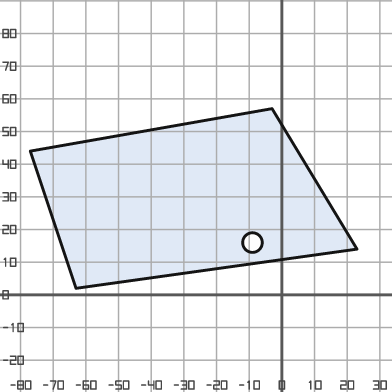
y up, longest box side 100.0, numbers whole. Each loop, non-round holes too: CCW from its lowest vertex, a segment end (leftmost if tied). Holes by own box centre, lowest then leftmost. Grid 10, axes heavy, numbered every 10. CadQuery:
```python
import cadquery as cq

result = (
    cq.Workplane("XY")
    .moveTo(-63.0, 2.0)
    .lineTo(23.0, 14.0)
    .lineTo(-3.0, 57.0)
    .lineTo(-77.0, 44.0)
    .close()
    .moveTo(-9.0, 16.0)
    .circle(3.0)
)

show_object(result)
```